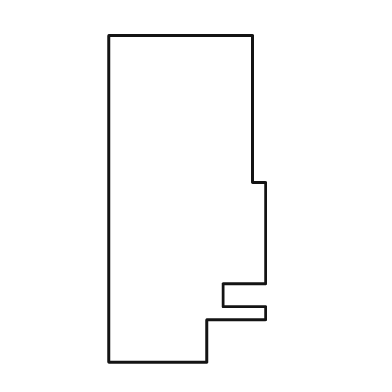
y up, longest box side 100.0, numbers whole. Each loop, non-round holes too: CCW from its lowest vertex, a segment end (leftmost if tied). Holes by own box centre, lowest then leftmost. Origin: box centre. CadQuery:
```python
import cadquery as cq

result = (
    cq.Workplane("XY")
    .moveTo(-24.0, -50.0)
    .lineTo(6.0, -50.0)
    .lineTo(6.0, -37.0)
    .lineTo(24.0, -37.0)
    .lineTo(24.0, -33.0)
    .lineTo(11.0, -33.0)
    .lineTo(11.0, -26.0)
    .lineTo(24.0, -26.0)
    .lineTo(24.0, 5.0)
    .lineTo(20.0, 5.0)
    .lineTo(20.0, 50.0)
    .lineTo(-24.0, 50.0)
    .close()
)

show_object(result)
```